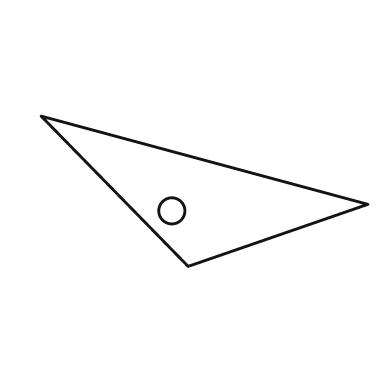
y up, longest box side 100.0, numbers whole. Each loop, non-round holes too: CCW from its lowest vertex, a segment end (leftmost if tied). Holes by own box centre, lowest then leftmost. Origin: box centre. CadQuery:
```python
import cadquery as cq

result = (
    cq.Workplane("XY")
    .moveTo(-5.0, -23.0)
    .lineTo(50.0, -4.0)
    .lineTo(-50.0, 23.0)
    .close()
    .moveTo(-10.0, -6.0)
    .circle(4.0)
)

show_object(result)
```